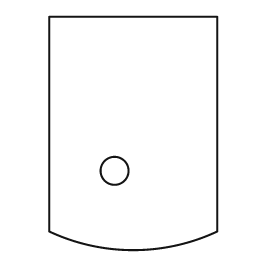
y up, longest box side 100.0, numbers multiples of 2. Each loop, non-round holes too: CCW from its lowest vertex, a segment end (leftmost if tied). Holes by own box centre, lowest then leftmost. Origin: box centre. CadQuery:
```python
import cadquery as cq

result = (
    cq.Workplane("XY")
    .moveTo(-36.0, -42.0)
    .threePointArc((0.0, -50.0), (36.0, -42.0))
    .lineTo(36.0, 50.0)
    .lineTo(-36.0, 50.0)
    .close()
    .moveTo(-8.0, -16.0)
    .circle(6.0)
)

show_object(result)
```